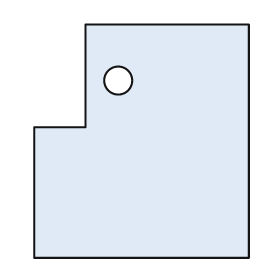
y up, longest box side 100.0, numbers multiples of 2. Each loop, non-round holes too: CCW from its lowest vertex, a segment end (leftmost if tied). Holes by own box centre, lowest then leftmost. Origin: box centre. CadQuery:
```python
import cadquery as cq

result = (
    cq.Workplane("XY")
    .moveTo(-46.0, -50.0)
    .lineTo(46.0, -50.0)
    .lineTo(46.0, 50.0)
    .lineTo(-24.0, 50.0)
    .lineTo(-24.0, 6.0)
    .lineTo(-46.0, 6.0)
    .close()
    .moveTo(-10.0, 26.0)
    .circle(6.0)
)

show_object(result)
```